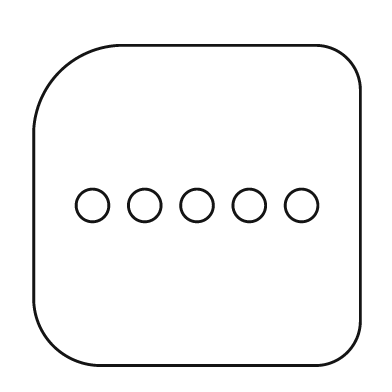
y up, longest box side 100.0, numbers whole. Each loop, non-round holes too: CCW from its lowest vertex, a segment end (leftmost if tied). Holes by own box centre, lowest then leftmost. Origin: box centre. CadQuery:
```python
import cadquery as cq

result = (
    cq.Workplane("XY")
    .moveTo(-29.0, -49.0)
    .lineTo(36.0, -49.0)
    .threePointArc((46.0, -45.0), (50.0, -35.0))
    .lineTo(50.0, 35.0)
    .threePointArc((46.0, 45.0), (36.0, 49.0))
    .lineTo(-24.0, 49.0)
    .threePointArc((-42.0, 41.0), (-50.0, 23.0))
    .lineTo(-50.0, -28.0)
    .threePointArc((-44.0, -43.0), (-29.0, -49.0))
    .close()
    .moveTo(-32.0, 0.0)
    .circle(5.0)
    .moveTo(-16.0, 0.0)
    .circle(5.0)
    .moveTo(0.0, 0.0)
    .circle(5.0)
    .moveTo(16.0, 0.0)
    .circle(5.0)
    .moveTo(32.0, 0.0)
    .circle(5.0)
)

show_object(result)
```